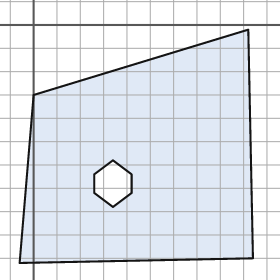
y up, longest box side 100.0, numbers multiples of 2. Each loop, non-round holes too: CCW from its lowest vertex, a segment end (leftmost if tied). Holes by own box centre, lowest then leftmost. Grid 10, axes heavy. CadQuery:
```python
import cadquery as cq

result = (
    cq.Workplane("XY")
    .moveTo(-6.0, -102.0)
    .lineTo(94.0, -100.0)
    .lineTo(92.0, -2.0)
    .lineTo(0.0, -30.0)
    .close()
    .moveTo(34.0, -78.0)
    .lineTo(42.0, -72.0)
    .lineTo(42.0, -64.0)
    .lineTo(34.0, -58.0)
    .lineTo(26.0, -64.0)
    .lineTo(26.0, -72.0)
    .close()
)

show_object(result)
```